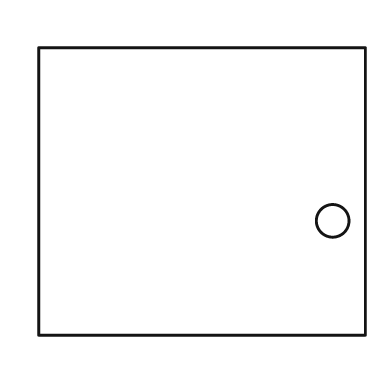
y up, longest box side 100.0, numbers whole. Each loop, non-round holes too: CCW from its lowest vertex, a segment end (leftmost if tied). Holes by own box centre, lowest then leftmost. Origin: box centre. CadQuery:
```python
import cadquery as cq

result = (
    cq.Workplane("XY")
    .moveTo(-50.0, -44.0)
    .lineTo(50.0, -44.0)
    .lineTo(50.0, 44.0)
    .lineTo(-50.0, 44.0)
    .close()
    .moveTo(40.0, -9.0)
    .circle(5.0)
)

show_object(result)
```